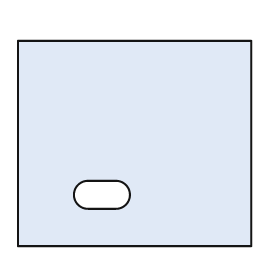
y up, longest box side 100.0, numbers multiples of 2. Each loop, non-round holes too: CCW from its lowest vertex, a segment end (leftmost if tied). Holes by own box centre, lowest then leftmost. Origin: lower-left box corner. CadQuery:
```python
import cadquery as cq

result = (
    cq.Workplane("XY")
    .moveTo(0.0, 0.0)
    .lineTo(100.0, 0.0)
    .lineTo(100.0, 88.0)
    .lineTo(0.0, 88.0)
    .close()
    .moveTo(30.0, 16.0)
    .lineTo(42.0, 16.0)
    .threePointArc((48.0, 22.0), (42.0, 28.0))
    .lineTo(30.0, 28.0)
    .threePointArc((24.0, 22.0), (30.0, 16.0))
    .close()
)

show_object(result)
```